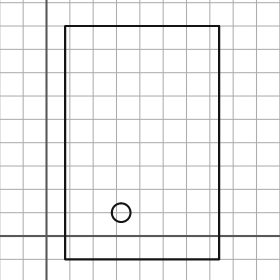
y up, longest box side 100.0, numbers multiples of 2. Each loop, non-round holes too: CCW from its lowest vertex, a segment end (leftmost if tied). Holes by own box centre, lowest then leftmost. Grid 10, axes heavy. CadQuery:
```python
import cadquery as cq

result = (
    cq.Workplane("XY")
    .moveTo(8.0, -10.0)
    .lineTo(74.0, -10.0)
    .lineTo(74.0, 90.0)
    .lineTo(8.0, 90.0)
    .close()
    .moveTo(32.0, 10.0)
    .circle(4.0)
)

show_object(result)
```